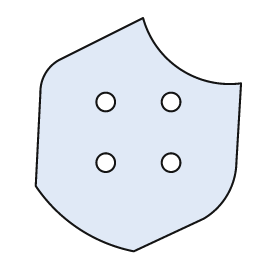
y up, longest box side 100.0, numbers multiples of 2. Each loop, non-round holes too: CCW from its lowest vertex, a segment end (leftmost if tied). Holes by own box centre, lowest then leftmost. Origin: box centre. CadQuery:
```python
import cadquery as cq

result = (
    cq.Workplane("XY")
    .moveTo(-2.0, -50.0)
    .lineTo(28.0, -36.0)
    .threePointArc((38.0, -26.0), (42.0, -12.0))
    .lineTo(44.0, 22.0)
    .threePointArc((18.0, 28.0), (2.0, 50.0))
    .lineTo(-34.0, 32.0)
    .threePointArc((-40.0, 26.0), (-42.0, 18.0))
    .lineTo(-44.0, -22.0)
    .threePointArc((-26.0, -40.0), (-2.0, -50.0))
    .close()
    .moveTo(-14.0, -12.0)
    .circle(4.0)
    .moveTo(14.0, -12.0)
    .circle(4.0)
    .moveTo(-14.0, 14.0)
    .circle(4.0)
    .moveTo(14.0, 14.0)
    .circle(4.0)
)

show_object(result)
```